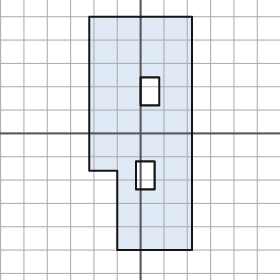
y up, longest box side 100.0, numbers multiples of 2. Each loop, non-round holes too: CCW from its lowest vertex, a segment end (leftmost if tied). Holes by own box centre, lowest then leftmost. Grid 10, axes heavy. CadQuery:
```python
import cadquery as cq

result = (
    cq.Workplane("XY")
    .moveTo(-10.0, -50.0)
    .lineTo(22.0, -50.0)
    .lineTo(22.0, 50.0)
    .lineTo(-22.0, 50.0)
    .lineTo(-22.0, -16.0)
    .lineTo(-10.0, -16.0)
    .close()
    .moveTo(-2.0, -24.0)
    .lineTo(6.0, -24.0)
    .lineTo(6.0, -12.0)
    .lineTo(-2.0, -12.0)
    .close()
    .moveTo(0.0, 12.0)
    .lineTo(8.0, 12.0)
    .lineTo(8.0, 24.0)
    .lineTo(0.0, 24.0)
    .close()
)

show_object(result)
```